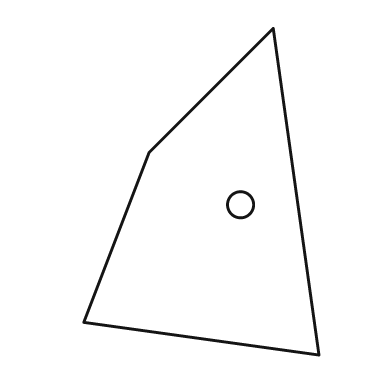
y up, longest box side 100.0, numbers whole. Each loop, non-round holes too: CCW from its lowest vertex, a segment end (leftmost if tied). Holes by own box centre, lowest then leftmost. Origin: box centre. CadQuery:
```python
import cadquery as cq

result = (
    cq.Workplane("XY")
    .moveTo(36.0, -50.0)
    .lineTo(22.0, 50.0)
    .lineTo(-16.0, 12.0)
    .lineTo(-36.0, -40.0)
    .close()
    .moveTo(12.0, -4.0)
    .circle(4.0)
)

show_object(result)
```